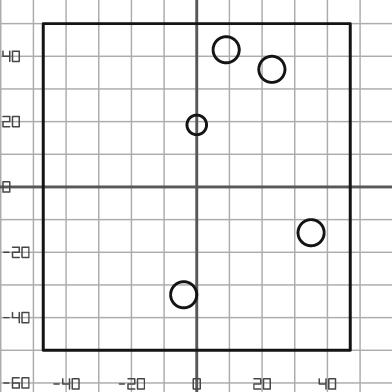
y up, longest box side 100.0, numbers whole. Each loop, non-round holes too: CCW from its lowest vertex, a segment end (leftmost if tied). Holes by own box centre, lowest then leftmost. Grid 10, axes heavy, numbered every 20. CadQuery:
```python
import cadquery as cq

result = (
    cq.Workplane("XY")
    .moveTo(-47.0, -50.0)
    .lineTo(47.0, -50.0)
    .lineTo(47.0, 50.0)
    .lineTo(-47.0, 50.0)
    .close()
    .moveTo(-4.0, -33.0)
    .circle(4.0)
    .moveTo(35.0, -14.0)
    .circle(4.0)
    .moveTo(0.0, 19.0)
    .circle(3.0)
    .moveTo(23.0, 36.0)
    .circle(4.0)
    .moveTo(9.0, 42.0)
    .circle(4.0)
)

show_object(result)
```